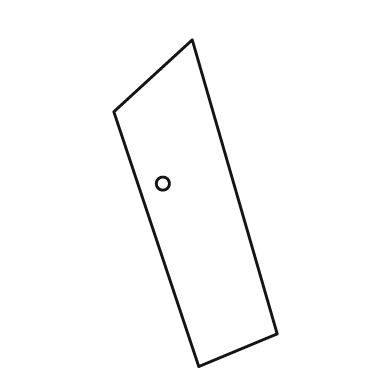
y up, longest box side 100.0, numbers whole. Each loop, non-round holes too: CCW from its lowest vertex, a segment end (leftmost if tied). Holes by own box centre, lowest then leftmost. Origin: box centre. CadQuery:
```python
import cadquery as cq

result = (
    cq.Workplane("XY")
    .moveTo(1.0, -50.0)
    .lineTo(25.0, -40.0)
    .lineTo(-1.0, 50.0)
    .lineTo(-25.0, 28.0)
    .close()
    .moveTo(-10.0, 6.0)
    .circle(2.0)
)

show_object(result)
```